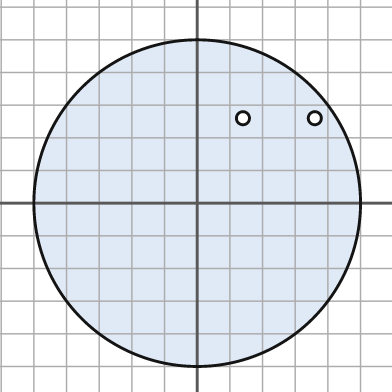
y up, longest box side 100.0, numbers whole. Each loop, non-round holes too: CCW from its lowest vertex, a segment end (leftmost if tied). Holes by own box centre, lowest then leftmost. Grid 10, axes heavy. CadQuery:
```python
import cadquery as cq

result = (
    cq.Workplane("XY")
    .moveTo(0.0, 0.0)
    .circle(50.0)
    .moveTo(14.0, 26.0)
    .circle(2.0)
    .moveTo(36.0, 26.0)
    .circle(2.0)
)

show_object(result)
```